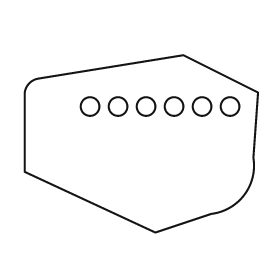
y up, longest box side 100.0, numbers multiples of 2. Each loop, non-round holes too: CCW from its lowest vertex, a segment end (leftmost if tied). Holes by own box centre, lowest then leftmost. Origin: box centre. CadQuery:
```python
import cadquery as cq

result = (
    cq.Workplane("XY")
    .moveTo(6.0, -38.0)
    .lineTo(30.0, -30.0)
    .threePointArc((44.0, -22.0), (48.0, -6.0))
    .lineTo(50.0, 22.0)
    .lineTo(18.0, 38.0)
    .lineTo(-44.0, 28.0)
    .threePointArc((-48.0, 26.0), (-50.0, 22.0))
    .lineTo(-50.0, -12.0)
    .close()
    .moveTo(-22.0, 16.0)
    .circle(4.0)
    .moveTo(-10.0, 16.0)
    .circle(4.0)
    .moveTo(2.0, 16.0)
    .circle(4.0)
    .moveTo(14.0, 16.0)
    .circle(4.0)
    .moveTo(26.0, 16.0)
    .circle(4.0)
    .moveTo(38.0, 16.0)
    .circle(4.0)
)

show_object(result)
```